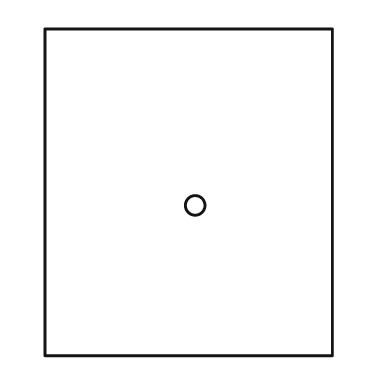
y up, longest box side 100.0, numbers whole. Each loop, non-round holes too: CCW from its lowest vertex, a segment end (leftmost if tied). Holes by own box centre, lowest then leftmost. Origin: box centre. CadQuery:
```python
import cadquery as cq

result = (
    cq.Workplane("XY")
    .moveTo(-44.0, -50.0)
    .lineTo(44.0, -50.0)
    .lineTo(44.0, 50.0)
    .lineTo(-44.0, 50.0)
    .close()
    .moveTo(2.0, -4.0)
    .circle(3.0)
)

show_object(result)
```